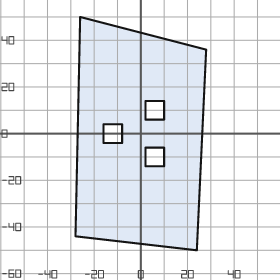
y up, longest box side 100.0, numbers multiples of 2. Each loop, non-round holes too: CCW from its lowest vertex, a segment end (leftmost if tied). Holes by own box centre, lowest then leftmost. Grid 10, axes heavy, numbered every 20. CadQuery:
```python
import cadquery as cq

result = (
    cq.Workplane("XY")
    .moveTo(24.0, -50.0)
    .lineTo(28.0, 36.0)
    .lineTo(-26.0, 50.0)
    .lineTo(-28.0, -44.0)
    .close()
    .moveTo(2.0, -14.0)
    .lineTo(10.0, -14.0)
    .lineTo(10.0, -6.0)
    .lineTo(2.0, -6.0)
    .close()
    .moveTo(-16.0, -4.0)
    .lineTo(-8.0, -4.0)
    .lineTo(-8.0, 4.0)
    .lineTo(-16.0, 4.0)
    .close()
    .moveTo(2.0, 6.0)
    .lineTo(10.0, 6.0)
    .lineTo(10.0, 14.0)
    .lineTo(2.0, 14.0)
    .close()
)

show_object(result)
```